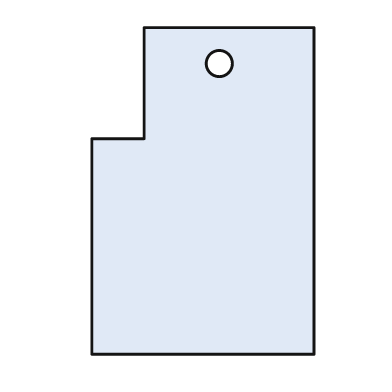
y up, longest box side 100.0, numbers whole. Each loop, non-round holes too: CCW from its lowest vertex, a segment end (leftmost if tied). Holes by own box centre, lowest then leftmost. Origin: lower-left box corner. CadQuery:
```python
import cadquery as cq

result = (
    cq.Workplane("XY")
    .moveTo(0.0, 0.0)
    .lineTo(68.0, 0.0)
    .lineTo(68.0, 100.0)
    .lineTo(16.0, 100.0)
    .lineTo(16.0, 66.0)
    .lineTo(0.0, 66.0)
    .close()
    .moveTo(39.0, 89.0)
    .circle(4.0)
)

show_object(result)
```